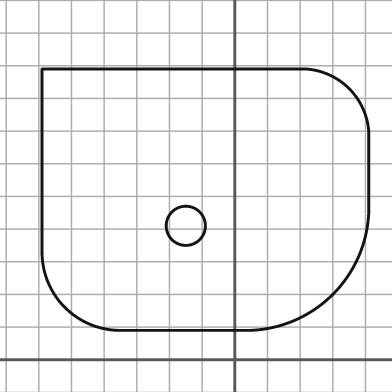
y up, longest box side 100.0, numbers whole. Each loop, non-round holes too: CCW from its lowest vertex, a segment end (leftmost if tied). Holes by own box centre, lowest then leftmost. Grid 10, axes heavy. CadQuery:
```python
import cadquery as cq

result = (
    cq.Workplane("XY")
    .moveTo(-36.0, 9.0)
    .lineTo(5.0, 9.0)
    .threePointArc((30.0, 20.0), (41.0, 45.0))
    .lineTo(41.0, 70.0)
    .threePointArc((35.0, 83.0), (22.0, 89.0))
    .lineTo(-59.0, 89.0)
    .lineTo(-59.0, 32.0)
    .threePointArc((-52.0, 16.0), (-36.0, 9.0))
    .close()
    .moveTo(-15.0, 41.0)
    .circle(6.0)
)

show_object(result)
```